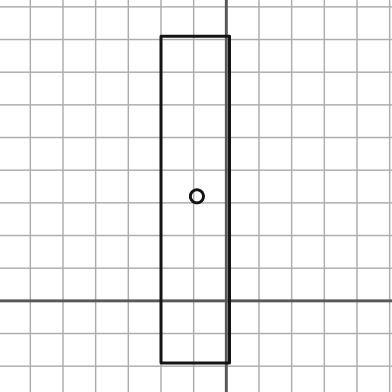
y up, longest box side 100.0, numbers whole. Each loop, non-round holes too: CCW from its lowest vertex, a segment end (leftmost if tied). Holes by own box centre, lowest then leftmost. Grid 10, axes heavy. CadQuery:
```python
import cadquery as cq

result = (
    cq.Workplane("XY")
    .moveTo(-20.0, -19.0)
    .lineTo(1.0, -19.0)
    .lineTo(1.0, 81.0)
    .lineTo(-20.0, 81.0)
    .close()
    .moveTo(-9.0, 32.0)
    .circle(2.0)
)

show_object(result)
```